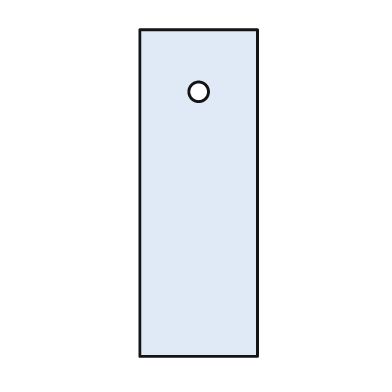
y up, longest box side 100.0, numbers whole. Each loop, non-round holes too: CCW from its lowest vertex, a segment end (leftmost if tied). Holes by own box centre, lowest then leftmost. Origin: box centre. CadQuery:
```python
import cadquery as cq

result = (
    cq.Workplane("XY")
    .moveTo(-18.0, -50.0)
    .lineTo(18.0, -50.0)
    .lineTo(18.0, 50.0)
    .lineTo(-18.0, 50.0)
    .close()
    .moveTo(0.0, 31.0)
    .circle(3.0)
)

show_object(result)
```